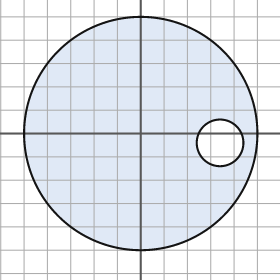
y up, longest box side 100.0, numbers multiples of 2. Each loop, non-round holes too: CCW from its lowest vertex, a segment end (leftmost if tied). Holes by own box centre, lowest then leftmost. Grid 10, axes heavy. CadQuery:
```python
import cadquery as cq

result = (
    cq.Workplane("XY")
    .moveTo(0.0, 0.0)
    .circle(50.0)
    .moveTo(34.0, -4.0)
    .circle(10.0)
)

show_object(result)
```